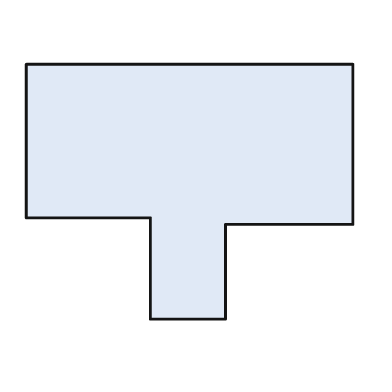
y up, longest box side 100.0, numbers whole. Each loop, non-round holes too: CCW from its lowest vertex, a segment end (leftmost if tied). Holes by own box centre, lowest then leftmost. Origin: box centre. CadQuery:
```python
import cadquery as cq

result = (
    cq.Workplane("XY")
    .moveTo(-12.0, -39.0)
    .lineTo(11.0, -39.0)
    .lineTo(11.0, -10.0)
    .lineTo(50.0, -10.0)
    .lineTo(50.0, 39.0)
    .lineTo(-50.0, 39.0)
    .lineTo(-50.0, -8.0)
    .lineTo(-12.0, -8.0)
    .close()
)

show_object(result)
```